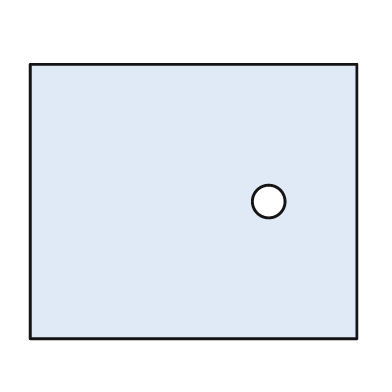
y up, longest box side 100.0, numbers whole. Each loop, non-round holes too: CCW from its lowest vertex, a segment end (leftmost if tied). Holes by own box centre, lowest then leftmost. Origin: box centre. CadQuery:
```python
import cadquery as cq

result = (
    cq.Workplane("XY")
    .moveTo(-50.0, -42.0)
    .lineTo(50.0, -42.0)
    .lineTo(50.0, 42.0)
    .lineTo(-50.0, 42.0)
    .close()
    .moveTo(23.0, 0.0)
    .circle(5.0)
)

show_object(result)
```